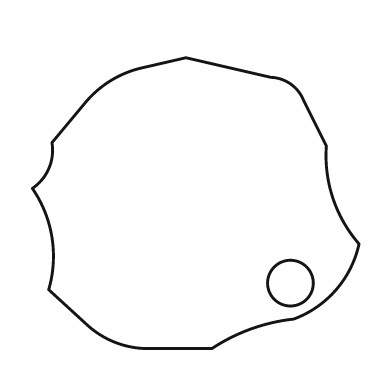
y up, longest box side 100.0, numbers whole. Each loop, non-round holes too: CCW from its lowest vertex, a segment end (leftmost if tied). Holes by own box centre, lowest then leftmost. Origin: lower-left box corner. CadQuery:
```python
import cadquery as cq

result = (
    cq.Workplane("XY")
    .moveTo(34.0, 0.0)
    .lineTo(55.0, 0.0)
    .threePointArc((67.0, 6.0), (80.0, 9.0))
    .threePointArc((93.0, 18.0), (100.0, 32.0))
    .threePointArc((92.0, 46.0), (90.0, 62.0))
    .lineTo(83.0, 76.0)
    .threePointArc((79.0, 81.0), (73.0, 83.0))
    .lineTo(47.0, 89.0)
    .lineTo(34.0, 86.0)
    .threePointArc((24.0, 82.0), (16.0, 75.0))
    .lineTo(6.0, 63.0)
    .threePointArc((5.0, 55.0), (0.0, 49.0))
    .threePointArc((6.0, 34.0), (5.0, 18.0))
    .lineTo(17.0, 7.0)
    .threePointArc((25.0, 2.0), (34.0, 0.0))
    .close()
    .moveTo(79.0, 20.0)
    .circle(7.0)
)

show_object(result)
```